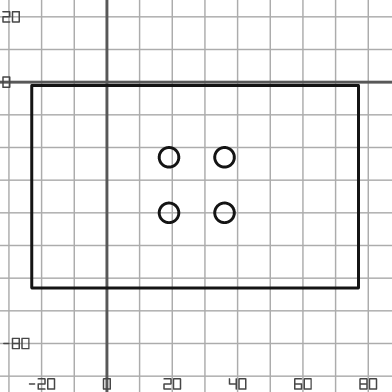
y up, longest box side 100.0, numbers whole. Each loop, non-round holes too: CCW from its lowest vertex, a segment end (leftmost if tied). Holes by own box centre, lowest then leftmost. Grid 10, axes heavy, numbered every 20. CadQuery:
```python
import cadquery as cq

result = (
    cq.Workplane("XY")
    .moveTo(-23.0, -63.0)
    .lineTo(77.0, -63.0)
    .lineTo(77.0, -1.0)
    .lineTo(-23.0, -1.0)
    .close()
    .moveTo(19.0, -40.0)
    .circle(3.0)
    .moveTo(36.0, -40.0)
    .circle(3.0)
    .moveTo(19.0, -23.0)
    .circle(3.0)
    .moveTo(36.0, -23.0)
    .circle(3.0)
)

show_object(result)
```